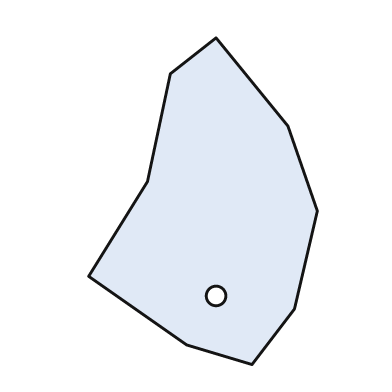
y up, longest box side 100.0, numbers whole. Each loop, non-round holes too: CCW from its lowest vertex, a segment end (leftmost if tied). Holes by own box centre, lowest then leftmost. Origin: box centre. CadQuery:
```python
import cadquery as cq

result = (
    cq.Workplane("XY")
    .moveTo(15.0, -50.0)
    .lineTo(28.0, -33.0)
    .lineTo(35.0, -3.0)
    .lineTo(26.0, 23.0)
    .lineTo(4.0, 50.0)
    .lineTo(-10.0, 39.0)
    .lineTo(-17.0, 6.0)
    .lineTo(-35.0, -23.0)
    .lineTo(-5.0, -44.0)
    .close()
    .moveTo(4.0, -29.0)
    .circle(3.0)
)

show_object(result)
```